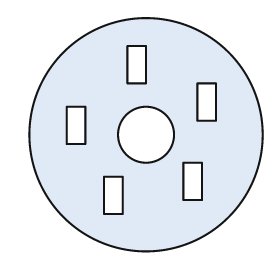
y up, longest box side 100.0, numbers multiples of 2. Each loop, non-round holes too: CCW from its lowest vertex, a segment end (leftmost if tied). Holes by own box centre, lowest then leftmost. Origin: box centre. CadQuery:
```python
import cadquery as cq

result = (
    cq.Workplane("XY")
    .moveTo(0.0, 0.0)
    .circle(50.0)
    .moveTo(-18.0, -34.0)
    .lineTo(-10.0, -34.0)
    .lineTo(-10.0, -18.0)
    .lineTo(-18.0, -18.0)
    .close()
    .moveTo(16.0, -28.0)
    .lineTo(24.0, -28.0)
    .lineTo(24.0, -12.0)
    .lineTo(16.0, -12.0)
    .close()
    .moveTo(0.0, 0.0)
    .circle(12.0)
    .moveTo(-34.0, -4.0)
    .lineTo(-26.0, -4.0)
    .lineTo(-26.0, 12.0)
    .lineTo(-34.0, 12.0)
    .close()
    .moveTo(22.0, 6.0)
    .lineTo(30.0, 6.0)
    .lineTo(30.0, 22.0)
    .lineTo(22.0, 22.0)
    .close()
    .moveTo(-8.0, 22.0)
    .lineTo(0.0, 22.0)
    .lineTo(0.0, 38.0)
    .lineTo(-8.0, 38.0)
    .close()
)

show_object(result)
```